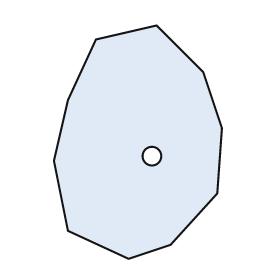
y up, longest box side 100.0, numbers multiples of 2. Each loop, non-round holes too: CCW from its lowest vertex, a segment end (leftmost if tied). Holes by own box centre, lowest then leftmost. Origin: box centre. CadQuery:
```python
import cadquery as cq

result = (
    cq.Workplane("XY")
    .moveTo(-4.0, -50.0)
    .lineTo(14.0, -44.0)
    .lineTo(34.0, -22.0)
    .lineTo(36.0, 6.0)
    .lineTo(28.0, 30.0)
    .lineTo(8.0, 50.0)
    .lineTo(-18.0, 44.0)
    .lineTo(-30.0, 18.0)
    .lineTo(-36.0, -8.0)
    .lineTo(-30.0, -38.0)
    .close()
    .moveTo(6.0, -6.0)
    .circle(4.0)
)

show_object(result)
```